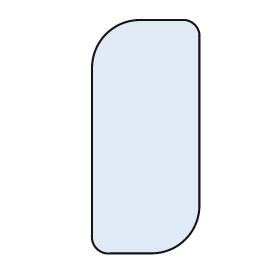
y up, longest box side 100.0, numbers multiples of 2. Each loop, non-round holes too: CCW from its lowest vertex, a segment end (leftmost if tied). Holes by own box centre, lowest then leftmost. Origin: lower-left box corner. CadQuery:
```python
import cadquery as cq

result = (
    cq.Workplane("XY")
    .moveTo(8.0, 0.0)
    .lineTo(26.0, 0.0)
    .threePointArc((40.0, 6.0), (46.0, 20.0))
    .lineTo(46.0, 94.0)
    .threePointArc((44.0, 98.0), (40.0, 100.0))
    .lineTo(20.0, 100.0)
    .threePointArc((6.0, 94.0), (0.0, 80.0))
    .lineTo(0.0, 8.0)
    .threePointArc((2.0, 2.0), (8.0, 0.0))
    .close()
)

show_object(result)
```